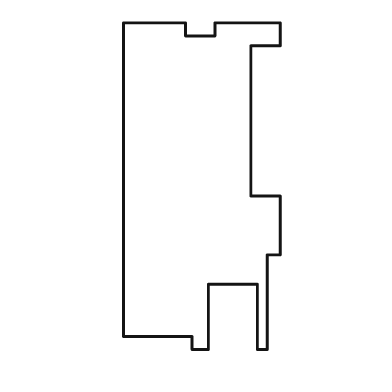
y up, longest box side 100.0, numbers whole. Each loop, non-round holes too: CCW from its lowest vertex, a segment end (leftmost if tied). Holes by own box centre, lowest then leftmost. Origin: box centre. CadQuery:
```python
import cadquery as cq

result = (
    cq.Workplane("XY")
    .moveTo(-3.0, -50.0)
    .lineTo(2.0, -50.0)
    .lineTo(2.0, -30.0)
    .lineTo(17.0, -30.0)
    .lineTo(17.0, -50.0)
    .lineTo(20.0, -50.0)
    .lineTo(20.0, -21.0)
    .lineTo(24.0, -21.0)
    .lineTo(24.0, -3.0)
    .lineTo(15.0, -3.0)
    .lineTo(15.0, 43.0)
    .lineTo(24.0, 43.0)
    .lineTo(24.0, 50.0)
    .lineTo(4.0, 50.0)
    .lineTo(4.0, 46.0)
    .lineTo(-5.0, 46.0)
    .lineTo(-5.0, 50.0)
    .lineTo(-24.0, 50.0)
    .lineTo(-24.0, -46.0)
    .lineTo(-3.0, -46.0)
    .close()
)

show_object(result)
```